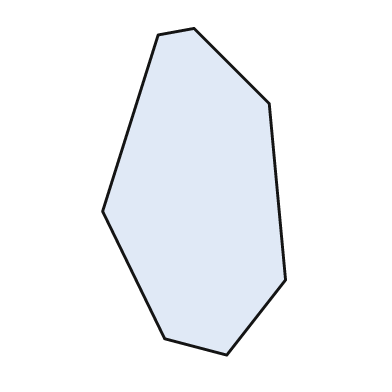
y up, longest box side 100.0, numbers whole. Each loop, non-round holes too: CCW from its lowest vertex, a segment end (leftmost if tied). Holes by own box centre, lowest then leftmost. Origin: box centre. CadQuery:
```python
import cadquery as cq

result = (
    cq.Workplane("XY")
    .moveTo(10.0, -50.0)
    .lineTo(28.0, -27.0)
    .lineTo(23.0, 27.0)
    .lineTo(0.0, 50.0)
    .lineTo(-11.0, 48.0)
    .lineTo(-28.0, -6.0)
    .lineTo(-9.0, -45.0)
    .close()
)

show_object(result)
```